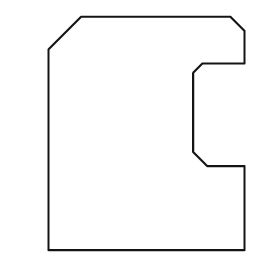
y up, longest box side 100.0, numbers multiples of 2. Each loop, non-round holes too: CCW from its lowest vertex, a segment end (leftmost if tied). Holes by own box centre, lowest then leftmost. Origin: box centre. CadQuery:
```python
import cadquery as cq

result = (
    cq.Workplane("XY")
    .moveTo(-42.0, -50.0)
    .lineTo(42.0, -50.0)
    .lineTo(42.0, -14.0)
    .lineTo(26.0, -14.0)
    .lineTo(20.0, -8.0)
    .lineTo(20.0, 26.0)
    .lineTo(24.0, 30.0)
    .lineTo(42.0, 30.0)
    .lineTo(42.0, 44.0)
    .lineTo(36.0, 50.0)
    .lineTo(-28.0, 50.0)
    .lineTo(-42.0, 36.0)
    .close()
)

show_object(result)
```